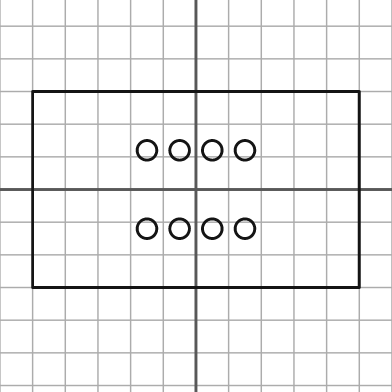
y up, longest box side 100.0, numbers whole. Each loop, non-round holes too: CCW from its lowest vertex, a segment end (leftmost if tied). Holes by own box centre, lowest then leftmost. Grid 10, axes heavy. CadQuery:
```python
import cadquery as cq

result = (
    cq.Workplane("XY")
    .moveTo(-50.0, -30.0)
    .lineTo(50.0, -30.0)
    .lineTo(50.0, 30.0)
    .lineTo(-50.0, 30.0)
    .close()
    .moveTo(-15.0, -12.0)
    .circle(3.0)
    .moveTo(-5.0, -12.0)
    .circle(3.0)
    .moveTo(5.0, -12.0)
    .circle(3.0)
    .moveTo(15.0, -12.0)
    .circle(3.0)
    .moveTo(-15.0, 12.0)
    .circle(3.0)
    .moveTo(-5.0, 12.0)
    .circle(3.0)
    .moveTo(5.0, 12.0)
    .circle(3.0)
    .moveTo(15.0, 12.0)
    .circle(3.0)
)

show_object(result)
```